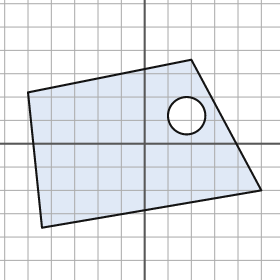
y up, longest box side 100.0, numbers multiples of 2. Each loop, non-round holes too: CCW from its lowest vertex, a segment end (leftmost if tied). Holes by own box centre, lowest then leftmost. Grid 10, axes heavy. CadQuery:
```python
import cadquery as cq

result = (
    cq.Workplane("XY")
    .moveTo(-44.0, -36.0)
    .lineTo(50.0, -20.0)
    .lineTo(20.0, 36.0)
    .lineTo(-50.0, 22.0)
    .close()
    .moveTo(18.0, 12.0)
    .circle(8.0)
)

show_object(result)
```